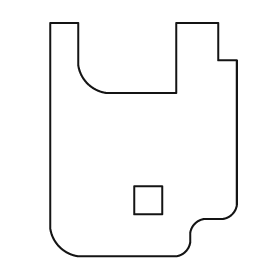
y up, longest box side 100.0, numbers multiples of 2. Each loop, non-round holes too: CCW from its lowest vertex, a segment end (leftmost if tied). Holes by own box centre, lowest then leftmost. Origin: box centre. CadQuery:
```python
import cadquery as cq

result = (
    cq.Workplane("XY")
    .moveTo(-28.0, -50.0)
    .lineTo(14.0, -50.0)
    .threePointArc((18.0, -48.0), (20.0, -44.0))
    .lineTo(20.0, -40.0)
    .threePointArc((22.0, -36.0), (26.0, -34.0))
    .lineTo(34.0, -34.0)
    .threePointArc((38.0, -32.0), (40.0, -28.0))
    .lineTo(40.0, 34.0)
    .lineTo(32.0, 34.0)
    .lineTo(32.0, 50.0)
    .lineTo(14.0, 50.0)
    .lineTo(14.0, 20.0)
    .lineTo(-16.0, 20.0)
    .threePointArc((-24.0, 24.0), (-28.0, 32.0))
    .lineTo(-28.0, 50.0)
    .lineTo(-40.0, 50.0)
    .lineTo(-40.0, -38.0)
    .threePointArc((-36.0, -46.0), (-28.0, -50.0))
    .close()
    .moveTo(-4.0, -32.0)
    .lineTo(8.0, -32.0)
    .lineTo(8.0, -20.0)
    .lineTo(-4.0, -20.0)
    .close()
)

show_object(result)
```